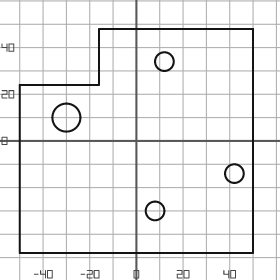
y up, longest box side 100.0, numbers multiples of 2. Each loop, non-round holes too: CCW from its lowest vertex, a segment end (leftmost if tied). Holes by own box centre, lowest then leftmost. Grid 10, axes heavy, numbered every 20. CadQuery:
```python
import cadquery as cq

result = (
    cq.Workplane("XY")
    .moveTo(-50.0, -48.0)
    .lineTo(50.0, -48.0)
    .lineTo(50.0, 48.0)
    .lineTo(-16.0, 48.0)
    .lineTo(-16.0, 24.0)
    .lineTo(-50.0, 24.0)
    .close()
    .moveTo(8.0, -30.0)
    .circle(4.0)
    .moveTo(42.0, -14.0)
    .circle(4.0)
    .moveTo(-30.0, 10.0)
    .circle(6.0)
    .moveTo(12.0, 34.0)
    .circle(4.0)
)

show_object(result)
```